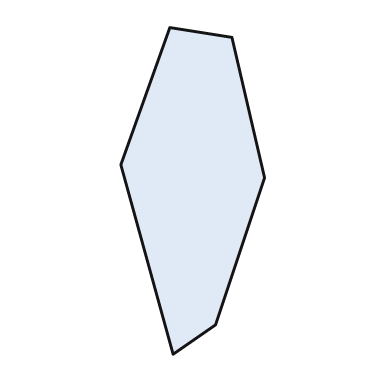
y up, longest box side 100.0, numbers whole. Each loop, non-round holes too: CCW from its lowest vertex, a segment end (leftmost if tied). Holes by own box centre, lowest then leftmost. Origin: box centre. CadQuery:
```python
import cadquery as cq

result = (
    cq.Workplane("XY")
    .moveTo(-6.0, -50.0)
    .lineTo(7.0, -41.0)
    .lineTo(22.0, 4.0)
    .lineTo(12.0, 47.0)
    .lineTo(-7.0, 50.0)
    .lineTo(-22.0, 8.0)
    .close()
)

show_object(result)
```